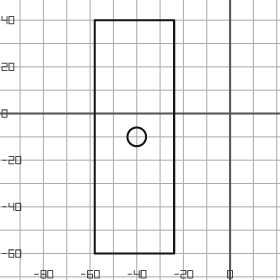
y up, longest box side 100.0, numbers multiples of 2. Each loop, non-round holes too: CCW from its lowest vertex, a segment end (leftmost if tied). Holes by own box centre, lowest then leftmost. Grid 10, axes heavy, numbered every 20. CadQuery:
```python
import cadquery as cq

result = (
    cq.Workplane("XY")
    .moveTo(-58.0, -60.0)
    .lineTo(-24.0, -60.0)
    .lineTo(-24.0, 40.0)
    .lineTo(-58.0, 40.0)
    .close()
    .moveTo(-40.0, -10.0)
    .circle(4.0)
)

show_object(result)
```